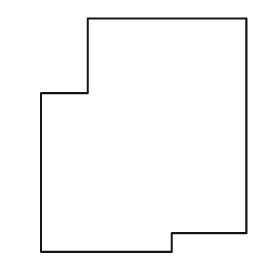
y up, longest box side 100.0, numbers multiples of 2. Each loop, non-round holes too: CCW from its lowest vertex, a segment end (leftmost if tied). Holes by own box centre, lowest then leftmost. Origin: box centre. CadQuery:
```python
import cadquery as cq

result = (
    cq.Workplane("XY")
    .moveTo(-44.0, -50.0)
    .lineTo(12.0, -50.0)
    .lineTo(12.0, -42.0)
    .lineTo(44.0, -42.0)
    .lineTo(44.0, 50.0)
    .lineTo(-24.0, 50.0)
    .lineTo(-24.0, 18.0)
    .lineTo(-44.0, 18.0)
    .close()
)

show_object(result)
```